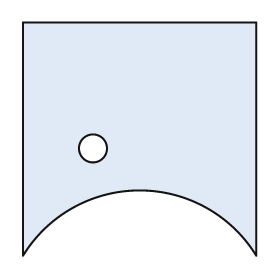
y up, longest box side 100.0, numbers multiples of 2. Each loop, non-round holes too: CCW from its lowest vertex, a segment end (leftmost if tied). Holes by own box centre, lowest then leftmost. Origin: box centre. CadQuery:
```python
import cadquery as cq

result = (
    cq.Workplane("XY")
    .moveTo(-50.0, -50.0)
    .threePointArc((0.0, -22.0), (50.0, -50.0))
    .lineTo(50.0, 50.0)
    .lineTo(-50.0, 50.0)
    .close()
    .moveTo(-20.0, -4.0)
    .circle(6.0)
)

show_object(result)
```